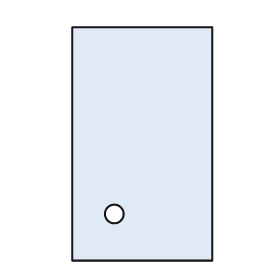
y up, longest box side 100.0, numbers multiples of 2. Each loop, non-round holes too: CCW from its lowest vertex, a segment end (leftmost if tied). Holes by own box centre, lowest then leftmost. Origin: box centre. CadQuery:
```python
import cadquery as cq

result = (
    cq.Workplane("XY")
    .moveTo(-30.0, -50.0)
    .lineTo(30.0, -50.0)
    .lineTo(30.0, 50.0)
    .lineTo(-30.0, 50.0)
    .close()
    .moveTo(-12.0, -30.0)
    .circle(4.0)
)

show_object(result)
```